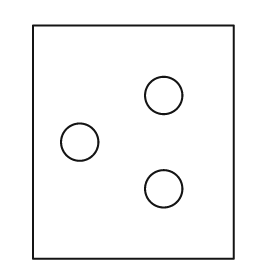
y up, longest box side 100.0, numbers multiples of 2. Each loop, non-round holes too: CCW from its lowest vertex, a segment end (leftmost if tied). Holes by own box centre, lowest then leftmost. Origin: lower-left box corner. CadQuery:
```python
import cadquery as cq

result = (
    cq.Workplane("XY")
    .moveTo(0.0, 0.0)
    .lineTo(86.0, 0.0)
    .lineTo(86.0, 100.0)
    .lineTo(0.0, 100.0)
    .close()
    .moveTo(56.0, 30.0)
    .circle(8.0)
    .moveTo(20.0, 50.0)
    .circle(8.0)
    .moveTo(56.0, 70.0)
    .circle(8.0)
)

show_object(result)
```